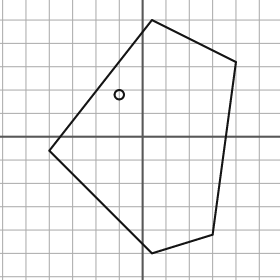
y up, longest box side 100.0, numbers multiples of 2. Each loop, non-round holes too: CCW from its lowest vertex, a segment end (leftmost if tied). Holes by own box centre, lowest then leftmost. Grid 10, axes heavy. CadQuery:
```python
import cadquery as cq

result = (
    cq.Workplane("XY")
    .moveTo(4.0, -50.0)
    .lineTo(30.0, -42.0)
    .lineTo(40.0, 32.0)
    .lineTo(4.0, 50.0)
    .lineTo(-40.0, -6.0)
    .close()
    .moveTo(-10.0, 18.0)
    .circle(2.0)
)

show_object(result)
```